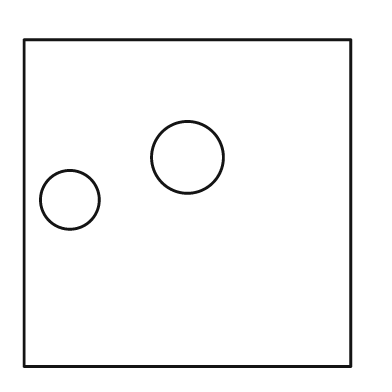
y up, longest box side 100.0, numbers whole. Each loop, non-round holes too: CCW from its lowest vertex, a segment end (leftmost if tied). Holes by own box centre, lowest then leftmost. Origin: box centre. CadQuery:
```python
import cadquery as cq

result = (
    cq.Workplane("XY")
    .moveTo(-50.0, -50.0)
    .lineTo(50.0, -50.0)
    .lineTo(50.0, 50.0)
    .lineTo(-50.0, 50.0)
    .close()
    .moveTo(-36.0, 1.0)
    .circle(9.0)
    .moveTo(0.0, 14.0)
    .circle(11.0)
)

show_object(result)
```